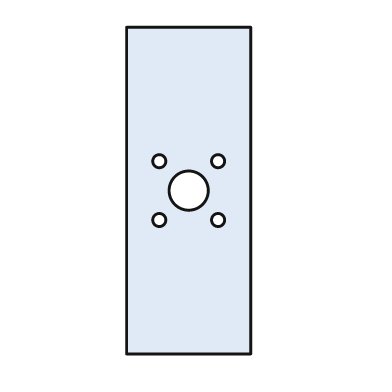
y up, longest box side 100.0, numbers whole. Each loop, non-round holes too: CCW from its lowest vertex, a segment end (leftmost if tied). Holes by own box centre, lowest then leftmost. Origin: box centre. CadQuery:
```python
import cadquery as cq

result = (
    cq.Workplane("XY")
    .moveTo(-19.0, -50.0)
    .lineTo(19.0, -50.0)
    .lineTo(19.0, 50.0)
    .lineTo(-19.0, 50.0)
    .close()
    .moveTo(-9.0, -9.0)
    .circle(2.0)
    .moveTo(9.0, -9.0)
    .circle(2.0)
    .moveTo(0.0, 0.0)
    .circle(6.0)
    .moveTo(-9.0, 9.0)
    .circle(2.0)
    .moveTo(9.0, 9.0)
    .circle(2.0)
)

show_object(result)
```